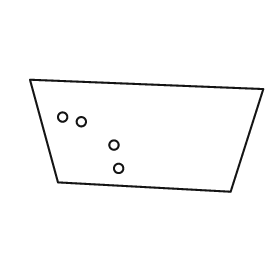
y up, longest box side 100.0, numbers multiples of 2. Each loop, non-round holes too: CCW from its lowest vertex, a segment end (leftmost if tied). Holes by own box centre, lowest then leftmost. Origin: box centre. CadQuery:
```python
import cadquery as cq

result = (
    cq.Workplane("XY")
    .moveTo(36.0, -24.0)
    .lineTo(50.0, 20.0)
    .lineTo(-50.0, 24.0)
    .lineTo(-38.0, -20.0)
    .close()
    .moveTo(-12.0, -14.0)
    .circle(2.0)
    .moveTo(-14.0, -4.0)
    .circle(2.0)
    .moveTo(-28.0, 6.0)
    .circle(2.0)
    .moveTo(-36.0, 8.0)
    .circle(2.0)
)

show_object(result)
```